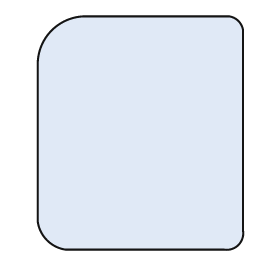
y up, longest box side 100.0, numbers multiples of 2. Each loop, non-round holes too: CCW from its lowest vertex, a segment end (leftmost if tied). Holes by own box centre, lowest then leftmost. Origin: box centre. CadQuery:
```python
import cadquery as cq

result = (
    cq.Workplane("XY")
    .moveTo(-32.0, -50.0)
    .lineTo(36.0, -50.0)
    .threePointArc((42.0, -48.0), (44.0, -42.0))
    .lineTo(44.0, 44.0)
    .threePointArc((42.0, 48.0), (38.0, 50.0))
    .lineTo(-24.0, 50.0)
    .threePointArc((-38.0, 44.0), (-44.0, 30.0))
    .lineTo(-44.0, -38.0)
    .threePointArc((-40.0, -46.0), (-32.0, -50.0))
    .close()
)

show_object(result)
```